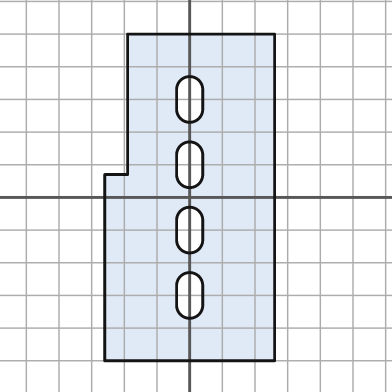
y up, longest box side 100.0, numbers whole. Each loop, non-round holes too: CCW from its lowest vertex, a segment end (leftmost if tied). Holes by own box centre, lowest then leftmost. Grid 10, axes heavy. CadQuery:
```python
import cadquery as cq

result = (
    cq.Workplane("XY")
    .moveTo(-26.0, -50.0)
    .lineTo(26.0, -50.0)
    .lineTo(26.0, 50.0)
    .lineTo(-19.0, 50.0)
    .lineTo(-19.0, 7.0)
    .lineTo(-26.0, 7.0)
    .close()
    .moveTo(-4.0, -33.0)
    .threePointArc((0.0, -37.0), (4.0, -33.0))
    .lineTo(4.0, -27.0)
    .threePointArc((0.0, -23.0), (-4.0, -27.0))
    .close()
    .moveTo(-4.0, -13.0)
    .threePointArc((0.0, -17.0), (4.0, -13.0))
    .lineTo(4.0, -7.0)
    .threePointArc((0.0, -3.0), (-4.0, -7.0))
    .close()
    .moveTo(-4.0, 7.0)
    .threePointArc((0.0, 3.0), (4.0, 7.0))
    .lineTo(4.0, 13.0)
    .threePointArc((0.0, 17.0), (-4.0, 13.0))
    .close()
    .moveTo(-4.0, 27.0)
    .threePointArc((0.0, 23.0), (4.0, 27.0))
    .lineTo(4.0, 33.0)
    .threePointArc((0.0, 37.0), (-4.0, 33.0))
    .close()
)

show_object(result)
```